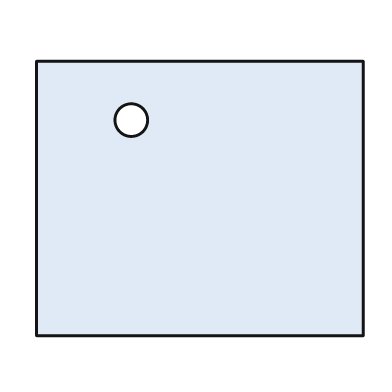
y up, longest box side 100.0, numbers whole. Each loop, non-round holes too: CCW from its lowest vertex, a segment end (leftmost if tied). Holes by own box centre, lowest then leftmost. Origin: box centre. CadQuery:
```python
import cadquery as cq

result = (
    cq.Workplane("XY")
    .moveTo(-50.0, -42.0)
    .lineTo(50.0, -42.0)
    .lineTo(50.0, 42.0)
    .lineTo(-50.0, 42.0)
    .close()
    .moveTo(-21.0, 24.0)
    .circle(5.0)
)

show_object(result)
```